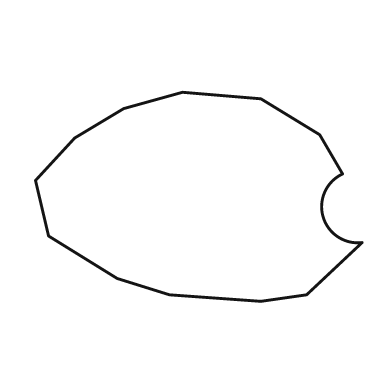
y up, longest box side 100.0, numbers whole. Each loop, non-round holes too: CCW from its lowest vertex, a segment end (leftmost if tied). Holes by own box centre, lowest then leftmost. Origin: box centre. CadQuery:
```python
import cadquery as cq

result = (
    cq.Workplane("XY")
    .moveTo(19.0, -32.0)
    .lineTo(33.0, -30.0)
    .lineTo(50.0, -14.0)
    .threePointArc((38.0, -6.0), (44.0, 7.0))
    .lineTo(37.0, 19.0)
    .lineTo(19.0, 30.0)
    .lineTo(-5.0, 32.0)
    .lineTo(-23.0, 27.0)
    .lineTo(-38.0, 18.0)
    .lineTo(-50.0, 5.0)
    .lineTo(-46.0, -12.0)
    .lineTo(-25.0, -25.0)
    .lineTo(-9.0, -30.0)
    .close()
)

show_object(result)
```